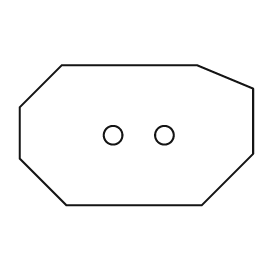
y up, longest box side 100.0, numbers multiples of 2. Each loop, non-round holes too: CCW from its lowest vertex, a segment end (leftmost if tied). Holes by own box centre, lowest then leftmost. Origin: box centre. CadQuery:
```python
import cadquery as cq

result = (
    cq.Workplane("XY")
    .moveTo(-30.0, -30.0)
    .lineTo(28.0, -30.0)
    .lineTo(50.0, -8.0)
    .lineTo(50.0, 20.0)
    .lineTo(26.0, 30.0)
    .lineTo(-32.0, 30.0)
    .lineTo(-50.0, 12.0)
    .lineTo(-50.0, -10.0)
    .close()
    .moveTo(-10.0, 0.0)
    .circle(4.0)
    .moveTo(12.0, 0.0)
    .circle(4.0)
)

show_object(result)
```